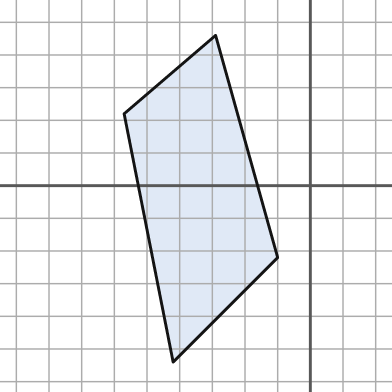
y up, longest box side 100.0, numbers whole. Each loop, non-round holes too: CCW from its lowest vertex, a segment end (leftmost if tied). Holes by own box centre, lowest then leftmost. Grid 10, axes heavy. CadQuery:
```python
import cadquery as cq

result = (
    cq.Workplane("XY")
    .moveTo(-42.0, -54.0)
    .lineTo(-10.0, -22.0)
    .lineTo(-29.0, 46.0)
    .lineTo(-57.0, 22.0)
    .close()
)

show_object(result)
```